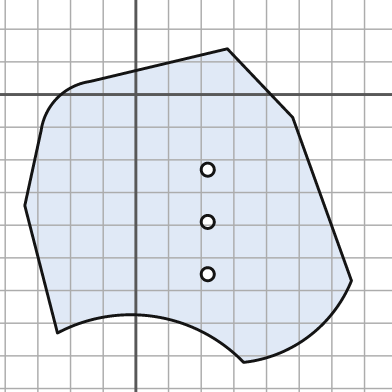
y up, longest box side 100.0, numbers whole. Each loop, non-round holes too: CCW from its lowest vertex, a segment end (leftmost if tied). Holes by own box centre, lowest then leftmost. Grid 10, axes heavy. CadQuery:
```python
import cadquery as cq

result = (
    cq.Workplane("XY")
    .moveTo(33.0, -82.0)
    .threePointArc((53.0, -74.0), (66.0, -57.0))
    .lineTo(48.0, -7.0)
    .lineTo(28.0, 14.0)
    .lineTo(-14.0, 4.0)
    .threePointArc((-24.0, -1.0), (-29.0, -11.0))
    .lineTo(-34.0, -34.0)
    .lineTo(-24.0, -73.0)
    .threePointArc((6.0, -68.0), (33.0, -82.0))
    .close()
    .moveTo(22.0, -55.0)
    .circle(2.0)
    .moveTo(22.0, -39.0)
    .circle(2.0)
    .moveTo(22.0, -23.0)
    .circle(2.0)
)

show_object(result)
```